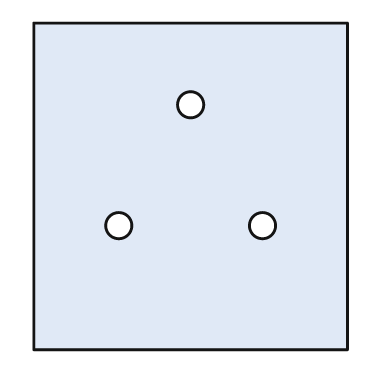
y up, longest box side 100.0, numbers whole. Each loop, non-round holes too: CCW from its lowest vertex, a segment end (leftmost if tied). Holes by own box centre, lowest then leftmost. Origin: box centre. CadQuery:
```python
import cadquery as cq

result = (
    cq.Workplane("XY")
    .moveTo(-48.0, -50.0)
    .lineTo(48.0, -50.0)
    .lineTo(48.0, 50.0)
    .lineTo(-48.0, 50.0)
    .close()
    .moveTo(-22.0, -12.0)
    .circle(4.0)
    .moveTo(22.0, -12.0)
    .circle(4.0)
    .moveTo(0.0, 25.0)
    .circle(4.0)
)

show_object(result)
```